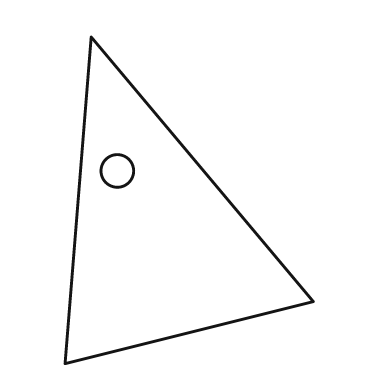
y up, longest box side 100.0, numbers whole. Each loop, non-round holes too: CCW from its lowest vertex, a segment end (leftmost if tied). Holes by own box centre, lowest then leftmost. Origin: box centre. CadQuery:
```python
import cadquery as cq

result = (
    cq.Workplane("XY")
    .moveTo(-38.0, -50.0)
    .lineTo(38.0, -31.0)
    .lineTo(-30.0, 50.0)
    .close()
    .moveTo(-22.0, 9.0)
    .circle(5.0)
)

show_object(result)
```